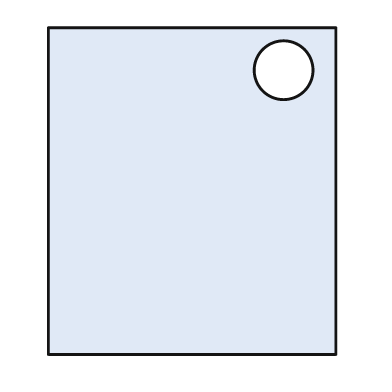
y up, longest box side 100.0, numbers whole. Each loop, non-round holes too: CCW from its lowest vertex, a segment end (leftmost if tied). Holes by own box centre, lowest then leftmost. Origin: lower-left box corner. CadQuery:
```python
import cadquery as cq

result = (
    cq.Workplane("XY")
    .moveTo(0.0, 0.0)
    .lineTo(88.0, 0.0)
    .lineTo(88.0, 100.0)
    .lineTo(0.0, 100.0)
    .close()
    .moveTo(72.0, 87.0)
    .circle(9.0)
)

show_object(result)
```